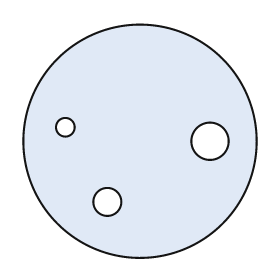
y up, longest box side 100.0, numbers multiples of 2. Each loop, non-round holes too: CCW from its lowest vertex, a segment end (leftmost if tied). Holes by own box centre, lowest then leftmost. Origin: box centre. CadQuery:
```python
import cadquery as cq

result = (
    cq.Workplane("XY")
    .moveTo(0.0, 0.0)
    .circle(50.0)
    .moveTo(-14.0, -26.0)
    .circle(6.0)
    .moveTo(30.0, 0.0)
    .circle(8.0)
    .moveTo(-32.0, 6.0)
    .circle(4.0)
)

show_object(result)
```